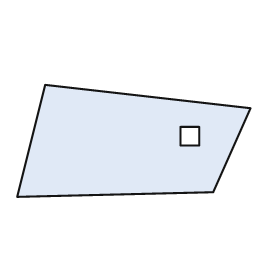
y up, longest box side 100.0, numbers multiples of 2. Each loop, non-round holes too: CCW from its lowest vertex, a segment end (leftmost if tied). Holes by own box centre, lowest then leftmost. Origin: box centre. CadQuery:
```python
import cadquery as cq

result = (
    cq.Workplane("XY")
    .moveTo(-50.0, -24.0)
    .lineTo(34.0, -22.0)
    .lineTo(50.0, 14.0)
    .lineTo(-38.0, 24.0)
    .close()
    .moveTo(20.0, -2.0)
    .lineTo(28.0, -2.0)
    .lineTo(28.0, 6.0)
    .lineTo(20.0, 6.0)
    .close()
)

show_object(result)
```